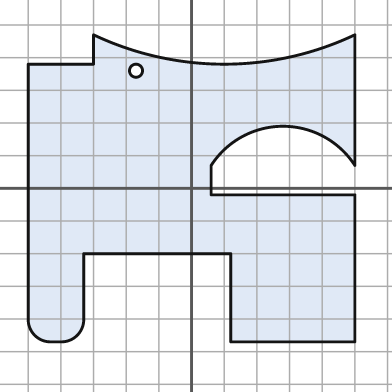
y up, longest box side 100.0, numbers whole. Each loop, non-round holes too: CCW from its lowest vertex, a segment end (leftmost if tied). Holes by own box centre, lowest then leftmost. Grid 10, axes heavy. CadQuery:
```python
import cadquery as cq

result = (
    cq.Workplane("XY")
    .moveTo(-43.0, -47.0)
    .lineTo(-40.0, -47.0)
    .threePointArc((-35.0, -45.0), (-33.0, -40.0))
    .lineTo(-33.0, -20.0)
    .lineTo(12.0, -20.0)
    .lineTo(12.0, -47.0)
    .lineTo(50.0, -47.0)
    .lineTo(50.0, -2.0)
    .lineTo(6.0, -2.0)
    .lineTo(6.0, 7.0)
    .threePointArc((28.0, 19.0), (50.0, 7.0))
    .lineTo(50.0, 47.0)
    .threePointArc((10.0, 38.0), (-30.0, 47.0))
    .lineTo(-30.0, 38.0)
    .lineTo(-50.0, 38.0)
    .lineTo(-50.0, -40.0)
    .threePointArc((-48.0, -45.0), (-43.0, -47.0))
    .close()
    .moveTo(-17.0, 36.0)
    .circle(2.0)
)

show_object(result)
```